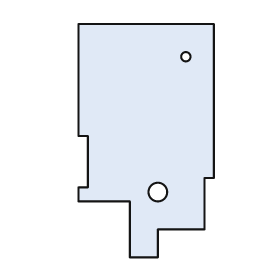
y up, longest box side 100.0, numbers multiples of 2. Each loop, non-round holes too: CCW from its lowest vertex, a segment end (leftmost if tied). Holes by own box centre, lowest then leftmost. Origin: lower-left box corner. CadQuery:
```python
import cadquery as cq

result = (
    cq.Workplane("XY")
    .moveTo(22.0, 0.0)
    .lineTo(34.0, 0.0)
    .lineTo(34.0, 12.0)
    .lineTo(54.0, 12.0)
    .lineTo(54.0, 34.0)
    .lineTo(58.0, 34.0)
    .lineTo(58.0, 100.0)
    .lineTo(0.0, 100.0)
    .lineTo(0.0, 52.0)
    .lineTo(4.0, 52.0)
    .lineTo(4.0, 30.0)
    .lineTo(0.0, 30.0)
    .lineTo(0.0, 24.0)
    .lineTo(22.0, 24.0)
    .close()
    .moveTo(34.0, 28.0)
    .circle(4.0)
    .moveTo(46.0, 86.0)
    .circle(2.0)
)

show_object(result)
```